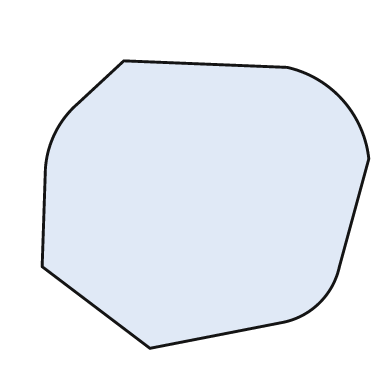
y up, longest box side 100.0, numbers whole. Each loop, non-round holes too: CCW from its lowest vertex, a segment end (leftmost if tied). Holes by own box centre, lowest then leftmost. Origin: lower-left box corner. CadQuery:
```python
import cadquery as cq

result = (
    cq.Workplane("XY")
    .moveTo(33.0, 0.0)
    .lineTo(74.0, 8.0)
    .threePointArc((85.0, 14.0), (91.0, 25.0))
    .lineTo(100.0, 58.0)
    .threePointArc((92.0, 76.0), (75.0, 86.0))
    .lineTo(25.0, 88.0)
    .lineTo(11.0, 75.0)
    .threePointArc((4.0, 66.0), (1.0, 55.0))
    .lineTo(0.0, 25.0)
    .close()
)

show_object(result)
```